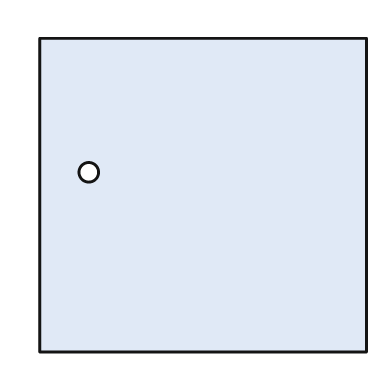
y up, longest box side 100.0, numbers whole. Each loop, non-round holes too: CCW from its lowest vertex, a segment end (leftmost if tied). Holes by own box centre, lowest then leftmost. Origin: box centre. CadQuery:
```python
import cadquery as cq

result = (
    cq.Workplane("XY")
    .moveTo(-50.0, -48.0)
    .lineTo(50.0, -48.0)
    .lineTo(50.0, 48.0)
    .lineTo(-50.0, 48.0)
    .close()
    .moveTo(-35.0, 7.0)
    .circle(3.0)
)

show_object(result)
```